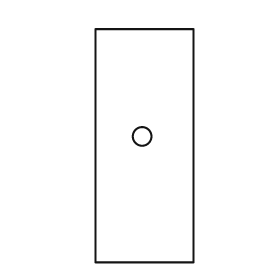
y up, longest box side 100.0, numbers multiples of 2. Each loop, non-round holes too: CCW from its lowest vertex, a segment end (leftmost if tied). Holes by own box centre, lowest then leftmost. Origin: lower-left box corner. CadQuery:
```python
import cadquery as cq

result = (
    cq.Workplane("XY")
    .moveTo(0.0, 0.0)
    .lineTo(42.0, 0.0)
    .lineTo(42.0, 100.0)
    .lineTo(0.0, 100.0)
    .close()
    .moveTo(20.0, 54.0)
    .circle(4.0)
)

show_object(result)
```